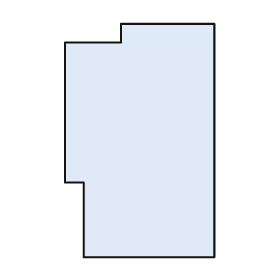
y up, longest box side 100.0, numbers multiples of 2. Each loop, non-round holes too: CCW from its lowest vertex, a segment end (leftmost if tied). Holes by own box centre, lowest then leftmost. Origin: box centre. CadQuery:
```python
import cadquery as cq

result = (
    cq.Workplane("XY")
    .moveTo(-24.0, -50.0)
    .lineTo(32.0, -50.0)
    .lineTo(32.0, 50.0)
    .lineTo(-8.0, 50.0)
    .lineTo(-8.0, 42.0)
    .lineTo(-32.0, 42.0)
    .lineTo(-32.0, -18.0)
    .lineTo(-24.0, -18.0)
    .close()
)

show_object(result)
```